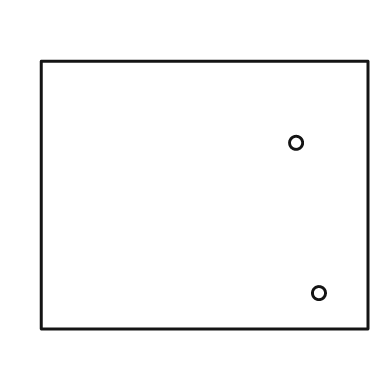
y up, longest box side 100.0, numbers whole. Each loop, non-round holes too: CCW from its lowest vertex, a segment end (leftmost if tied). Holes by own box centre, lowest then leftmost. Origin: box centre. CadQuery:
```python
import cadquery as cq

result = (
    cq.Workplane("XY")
    .moveTo(-50.0, -41.0)
    .lineTo(50.0, -41.0)
    .lineTo(50.0, 41.0)
    .lineTo(-50.0, 41.0)
    .close()
    .moveTo(35.0, -30.0)
    .circle(2.0)
    .moveTo(28.0, 16.0)
    .circle(2.0)
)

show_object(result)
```